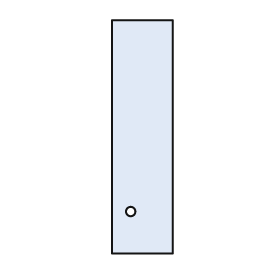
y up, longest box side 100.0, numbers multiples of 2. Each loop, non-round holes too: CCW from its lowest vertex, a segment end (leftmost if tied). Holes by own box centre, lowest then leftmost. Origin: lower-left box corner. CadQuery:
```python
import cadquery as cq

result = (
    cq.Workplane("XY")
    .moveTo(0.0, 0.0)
    .lineTo(26.0, 0.0)
    .lineTo(26.0, 100.0)
    .lineTo(0.0, 100.0)
    .close()
    .moveTo(8.0, 18.0)
    .circle(2.0)
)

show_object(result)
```